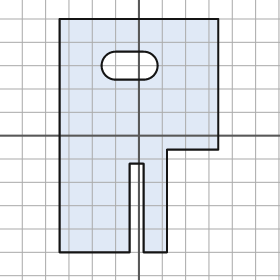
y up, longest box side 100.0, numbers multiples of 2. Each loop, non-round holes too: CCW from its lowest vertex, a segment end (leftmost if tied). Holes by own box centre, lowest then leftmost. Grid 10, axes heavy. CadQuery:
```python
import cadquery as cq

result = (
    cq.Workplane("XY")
    .moveTo(-34.0, -50.0)
    .lineTo(-4.0, -50.0)
    .lineTo(-4.0, -12.0)
    .lineTo(2.0, -12.0)
    .lineTo(2.0, -50.0)
    .lineTo(12.0, -50.0)
    .lineTo(12.0, -6.0)
    .lineTo(34.0, -6.0)
    .lineTo(34.0, 50.0)
    .lineTo(-34.0, 50.0)
    .close()
    .moveTo(-10.0, 24.0)
    .lineTo(2.0, 24.0)
    .threePointArc((8.0, 30.0), (2.0, 36.0))
    .lineTo(-10.0, 36.0)
    .threePointArc((-16.0, 30.0), (-10.0, 24.0))
    .close()
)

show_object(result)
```